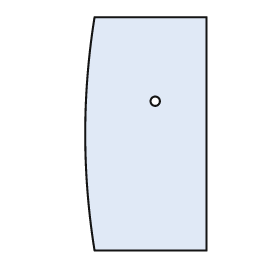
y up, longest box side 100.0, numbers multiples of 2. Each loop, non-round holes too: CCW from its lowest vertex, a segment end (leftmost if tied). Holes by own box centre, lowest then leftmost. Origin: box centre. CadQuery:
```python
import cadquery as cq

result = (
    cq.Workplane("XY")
    .moveTo(-22.0, -50.0)
    .lineTo(26.0, -50.0)
    .lineTo(26.0, 50.0)
    .lineTo(-22.0, 50.0)
    .threePointArc((-26.0, 0.0), (-22.0, -50.0))
    .close()
    .moveTo(4.0, 14.0)
    .circle(2.0)
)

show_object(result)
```